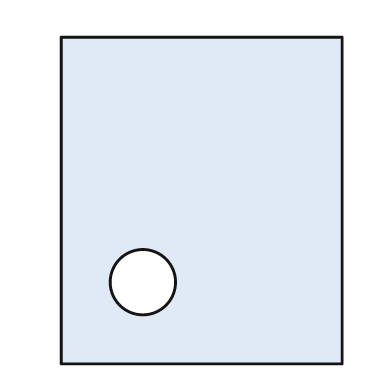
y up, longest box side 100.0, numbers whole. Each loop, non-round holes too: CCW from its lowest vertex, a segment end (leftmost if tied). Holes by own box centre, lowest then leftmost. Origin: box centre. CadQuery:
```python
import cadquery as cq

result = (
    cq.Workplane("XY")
    .moveTo(-43.0, -50.0)
    .lineTo(43.0, -50.0)
    .lineTo(43.0, 50.0)
    .lineTo(-43.0, 50.0)
    .close()
    .moveTo(-18.0, -25.0)
    .circle(10.0)
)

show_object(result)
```